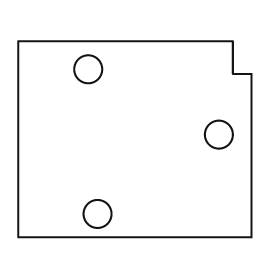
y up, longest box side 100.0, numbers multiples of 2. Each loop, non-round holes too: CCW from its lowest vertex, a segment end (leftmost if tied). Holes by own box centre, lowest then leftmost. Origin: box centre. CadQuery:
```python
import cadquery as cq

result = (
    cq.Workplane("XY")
    .moveTo(-50.0, -42.0)
    .lineTo(50.0, -42.0)
    .lineTo(50.0, 28.0)
    .lineTo(42.0, 28.0)
    .lineTo(42.0, 42.0)
    .lineTo(-50.0, 42.0)
    .close()
    .moveTo(-16.0, -32.0)
    .circle(6.0)
    .moveTo(36.0, 2.0)
    .circle(6.0)
    .moveTo(-20.0, 30.0)
    .circle(6.0)
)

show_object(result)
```